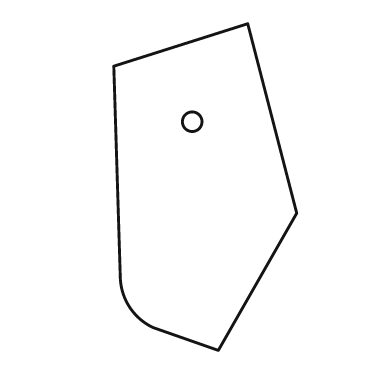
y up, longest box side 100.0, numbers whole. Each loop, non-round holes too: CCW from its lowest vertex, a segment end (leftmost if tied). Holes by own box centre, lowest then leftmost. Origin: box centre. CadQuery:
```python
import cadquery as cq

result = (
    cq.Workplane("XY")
    .moveTo(4.0, -50.0)
    .lineTo(28.0, -8.0)
    .lineTo(13.0, 50.0)
    .lineTo(-28.0, 37.0)
    .lineTo(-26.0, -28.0)
    .threePointArc((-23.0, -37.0), (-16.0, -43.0))
    .close()
    .moveTo(-4.0, 20.0)
    .circle(3.0)
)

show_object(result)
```